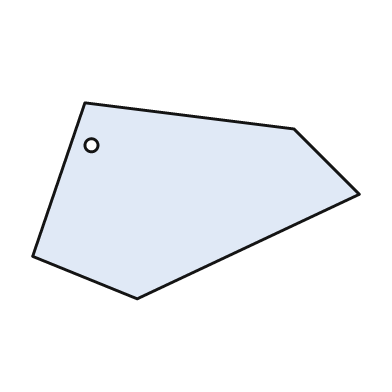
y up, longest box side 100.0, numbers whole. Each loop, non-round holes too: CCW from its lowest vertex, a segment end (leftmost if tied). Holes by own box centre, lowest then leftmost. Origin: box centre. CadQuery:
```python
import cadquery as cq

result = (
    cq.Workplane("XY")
    .moveTo(-18.0, -30.0)
    .lineTo(50.0, 2.0)
    .lineTo(30.0, 22.0)
    .lineTo(-34.0, 30.0)
    .lineTo(-50.0, -17.0)
    .close()
    .moveTo(-32.0, 17.0)
    .circle(2.0)
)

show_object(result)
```